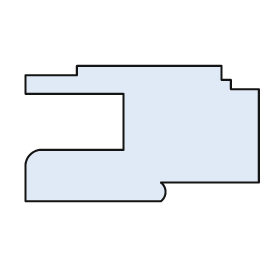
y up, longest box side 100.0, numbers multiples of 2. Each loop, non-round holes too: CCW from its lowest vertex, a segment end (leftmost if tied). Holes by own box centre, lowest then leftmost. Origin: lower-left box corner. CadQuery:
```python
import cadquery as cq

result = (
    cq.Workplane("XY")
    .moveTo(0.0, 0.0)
    .lineTo(58.0, 0.0)
    .threePointArc((60.0, 4.0), (58.0, 8.0))
    .lineTo(100.0, 8.0)
    .lineTo(100.0, 48.0)
    .lineTo(88.0, 48.0)
    .lineTo(88.0, 52.0)
    .lineTo(84.0, 52.0)
    .lineTo(84.0, 58.0)
    .lineTo(22.0, 58.0)
    .lineTo(22.0, 54.0)
    .lineTo(0.0, 54.0)
    .lineTo(0.0, 46.0)
    .lineTo(42.0, 46.0)
    .lineTo(42.0, 22.0)
    .lineTo(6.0, 22.0)
    .threePointArc((2.0, 20.0), (0.0, 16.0))
    .close()
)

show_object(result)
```